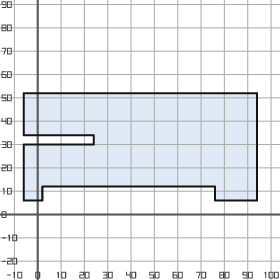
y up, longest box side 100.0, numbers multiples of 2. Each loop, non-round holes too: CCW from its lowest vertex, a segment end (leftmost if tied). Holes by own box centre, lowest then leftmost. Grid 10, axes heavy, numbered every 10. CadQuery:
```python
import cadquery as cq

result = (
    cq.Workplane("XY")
    .moveTo(-6.0, 6.0)
    .lineTo(2.0, 6.0)
    .lineTo(2.0, 12.0)
    .lineTo(76.0, 12.0)
    .lineTo(76.0, 6.0)
    .lineTo(94.0, 6.0)
    .lineTo(94.0, 52.0)
    .lineTo(-6.0, 52.0)
    .lineTo(-6.0, 34.0)
    .lineTo(24.0, 34.0)
    .lineTo(24.0, 30.0)
    .lineTo(-6.0, 30.0)
    .close()
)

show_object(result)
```